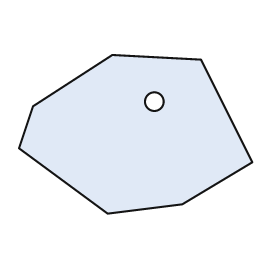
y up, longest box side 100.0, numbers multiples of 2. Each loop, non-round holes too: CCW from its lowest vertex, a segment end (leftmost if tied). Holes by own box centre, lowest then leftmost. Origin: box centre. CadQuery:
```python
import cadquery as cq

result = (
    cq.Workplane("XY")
    .moveTo(-12.0, -34.0)
    .lineTo(20.0, -30.0)
    .lineTo(50.0, -12.0)
    .lineTo(28.0, 32.0)
    .lineTo(-10.0, 34.0)
    .lineTo(-44.0, 12.0)
    .lineTo(-50.0, -6.0)
    .close()
    .moveTo(8.0, 14.0)
    .circle(4.0)
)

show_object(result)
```